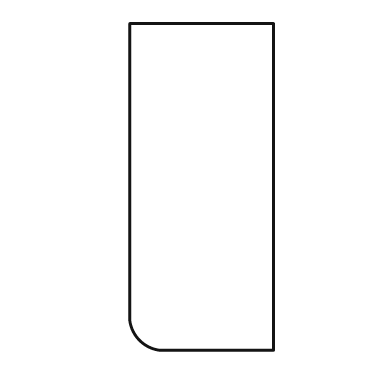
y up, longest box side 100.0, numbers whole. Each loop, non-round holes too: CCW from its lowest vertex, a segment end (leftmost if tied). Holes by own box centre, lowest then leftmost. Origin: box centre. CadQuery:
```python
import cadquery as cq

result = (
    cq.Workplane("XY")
    .moveTo(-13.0, -50.0)
    .lineTo(22.0, -50.0)
    .lineTo(22.0, 50.0)
    .lineTo(-22.0, 50.0)
    .lineTo(-22.0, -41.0)
    .threePointArc((-19.0, -47.0), (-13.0, -50.0))
    .close()
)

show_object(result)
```